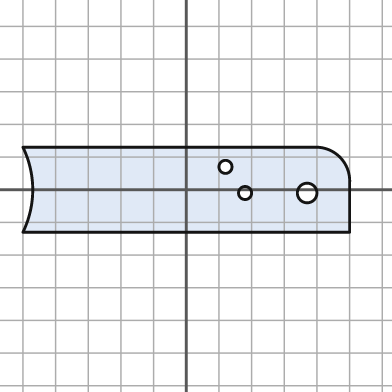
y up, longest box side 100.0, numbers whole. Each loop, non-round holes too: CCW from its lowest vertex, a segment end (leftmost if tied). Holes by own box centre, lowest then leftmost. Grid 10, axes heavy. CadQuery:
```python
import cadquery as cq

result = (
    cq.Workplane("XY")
    .moveTo(-50.0, -13.0)
    .lineTo(50.0, -13.0)
    .lineTo(50.0, 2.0)
    .threePointArc((47.0, 10.0), (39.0, 13.0))
    .lineTo(-50.0, 13.0)
    .threePointArc((-47.0, 0.0), (-50.0, -13.0))
    .close()
    .moveTo(18.0, -1.0)
    .circle(2.0)
    .moveTo(37.0, -1.0)
    .circle(3.0)
    .moveTo(12.0, 7.0)
    .circle(2.0)
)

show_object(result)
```